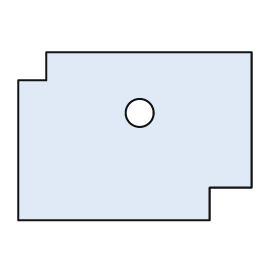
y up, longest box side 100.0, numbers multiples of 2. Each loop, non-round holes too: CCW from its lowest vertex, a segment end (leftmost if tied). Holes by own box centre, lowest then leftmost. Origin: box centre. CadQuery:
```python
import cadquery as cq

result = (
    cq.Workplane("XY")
    .moveTo(-50.0, -36.0)
    .lineTo(32.0, -36.0)
    .lineTo(32.0, -22.0)
    .lineTo(50.0, -22.0)
    .lineTo(50.0, 36.0)
    .lineTo(-38.0, 36.0)
    .lineTo(-38.0, 24.0)
    .lineTo(-50.0, 24.0)
    .close()
    .moveTo(2.0, 10.0)
    .circle(6.0)
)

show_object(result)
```